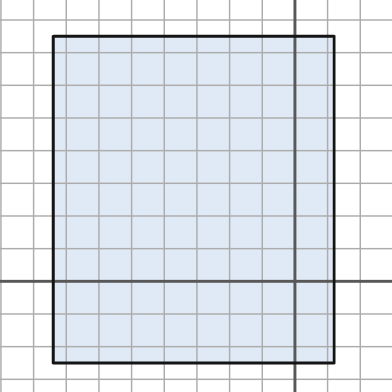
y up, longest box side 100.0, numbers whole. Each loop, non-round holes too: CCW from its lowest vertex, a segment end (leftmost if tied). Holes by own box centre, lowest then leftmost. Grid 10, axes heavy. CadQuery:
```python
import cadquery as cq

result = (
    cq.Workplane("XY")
    .moveTo(-74.0, -25.0)
    .lineTo(12.0, -25.0)
    .lineTo(12.0, 75.0)
    .lineTo(-74.0, 75.0)
    .close()
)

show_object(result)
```